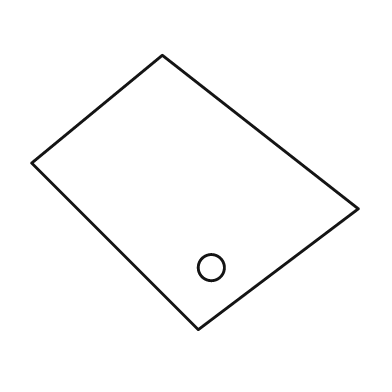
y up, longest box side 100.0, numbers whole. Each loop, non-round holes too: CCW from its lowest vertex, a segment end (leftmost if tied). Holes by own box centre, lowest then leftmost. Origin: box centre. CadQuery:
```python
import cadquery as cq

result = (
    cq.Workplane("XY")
    .moveTo(1.0, -42.0)
    .lineTo(50.0, -5.0)
    .lineTo(-10.0, 42.0)
    .lineTo(-50.0, 9.0)
    .close()
    .moveTo(5.0, -23.0)
    .circle(4.0)
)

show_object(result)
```